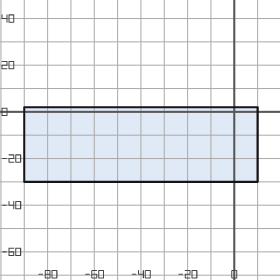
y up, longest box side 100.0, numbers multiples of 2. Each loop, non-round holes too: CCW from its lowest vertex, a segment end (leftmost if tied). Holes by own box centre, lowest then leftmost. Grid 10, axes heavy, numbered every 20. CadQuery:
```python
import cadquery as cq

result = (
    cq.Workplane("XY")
    .moveTo(-90.0, -30.0)
    .lineTo(10.0, -30.0)
    .lineTo(10.0, 2.0)
    .lineTo(-90.0, 2.0)
    .close()
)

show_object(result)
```